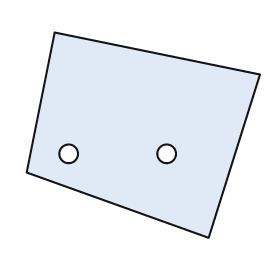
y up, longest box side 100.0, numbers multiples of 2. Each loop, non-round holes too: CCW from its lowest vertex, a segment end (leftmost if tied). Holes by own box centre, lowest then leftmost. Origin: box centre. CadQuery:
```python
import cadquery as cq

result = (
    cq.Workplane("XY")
    .moveTo(28.0, -44.0)
    .lineTo(50.0, 26.0)
    .lineTo(-38.0, 44.0)
    .lineTo(-50.0, -16.0)
    .close()
    .moveTo(-32.0, -8.0)
    .circle(4.0)
    .moveTo(10.0, -8.0)
    .circle(4.0)
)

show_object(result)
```